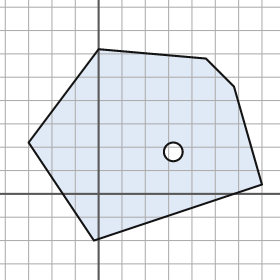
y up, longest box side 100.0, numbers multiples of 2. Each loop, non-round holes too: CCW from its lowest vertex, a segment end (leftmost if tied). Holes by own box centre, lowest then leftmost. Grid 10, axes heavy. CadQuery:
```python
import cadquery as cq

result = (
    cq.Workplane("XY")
    .moveTo(-2.0, -20.0)
    .lineTo(70.0, 4.0)
    .lineTo(58.0, 46.0)
    .lineTo(46.0, 58.0)
    .lineTo(0.0, 62.0)
    .lineTo(-30.0, 22.0)
    .close()
    .moveTo(32.0, 18.0)
    .circle(4.0)
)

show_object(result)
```